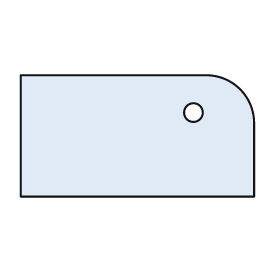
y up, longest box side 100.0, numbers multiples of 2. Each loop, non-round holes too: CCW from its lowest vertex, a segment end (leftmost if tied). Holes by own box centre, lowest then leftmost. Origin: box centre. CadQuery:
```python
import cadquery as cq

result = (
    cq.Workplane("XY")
    .moveTo(-50.0, -26.0)
    .lineTo(50.0, -26.0)
    .lineTo(50.0, 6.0)
    .threePointArc((44.0, 20.0), (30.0, 26.0))
    .lineTo(-50.0, 26.0)
    .close()
    .moveTo(24.0, 10.0)
    .circle(4.0)
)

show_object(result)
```